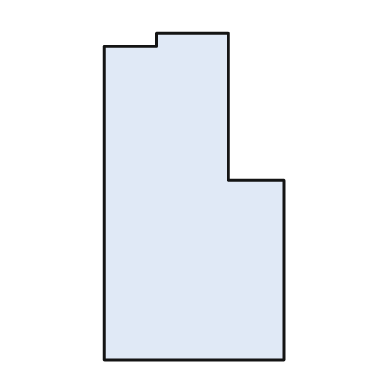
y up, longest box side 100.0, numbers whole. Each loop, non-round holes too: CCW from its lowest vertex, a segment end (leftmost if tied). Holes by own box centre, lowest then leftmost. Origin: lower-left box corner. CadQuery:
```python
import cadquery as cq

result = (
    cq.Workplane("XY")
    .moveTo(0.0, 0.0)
    .lineTo(55.0, 0.0)
    .lineTo(55.0, 55.0)
    .lineTo(38.0, 55.0)
    .lineTo(38.0, 100.0)
    .lineTo(16.0, 100.0)
    .lineTo(16.0, 96.0)
    .lineTo(0.0, 96.0)
    .close()
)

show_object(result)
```